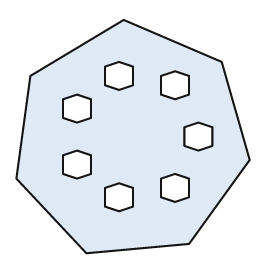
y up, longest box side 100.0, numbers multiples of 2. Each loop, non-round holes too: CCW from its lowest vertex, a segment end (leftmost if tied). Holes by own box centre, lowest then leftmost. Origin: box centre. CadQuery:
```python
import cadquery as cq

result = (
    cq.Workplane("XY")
    .moveTo(-20.0, -50.0)
    .lineTo(24.0, -46.0)
    .lineTo(50.0, -10.0)
    .lineTo(38.0, 32.0)
    .lineTo(-4.0, 50.0)
    .lineTo(-44.0, 26.0)
    .lineTo(-50.0, -18.0)
    .close()
    .moveTo(-6.0, -32.0)
    .lineTo(0.0, -30.0)
    .lineTo(0.0, -22.0)
    .lineTo(-6.0, -20.0)
    .lineTo(-12.0, -22.0)
    .lineTo(-12.0, -30.0)
    .close()
    .moveTo(18.0, -28.0)
    .lineTo(24.0, -26.0)
    .lineTo(24.0, -18.0)
    .lineTo(18.0, -16.0)
    .lineTo(12.0, -18.0)
    .lineTo(12.0, -26.0)
    .close()
    .moveTo(-24.0, -18.0)
    .lineTo(-18.0, -16.0)
    .lineTo(-18.0, -8.0)
    .lineTo(-24.0, -6.0)
    .lineTo(-30.0, -8.0)
    .lineTo(-30.0, -16.0)
    .close()
    .moveTo(28.0, -6.0)
    .lineTo(34.0, -4.0)
    .lineTo(34.0, 4.0)
    .lineTo(28.0, 6.0)
    .lineTo(22.0, 4.0)
    .lineTo(22.0, -4.0)
    .close()
    .moveTo(-24.0, 6.0)
    .lineTo(-18.0, 8.0)
    .lineTo(-18.0, 16.0)
    .lineTo(-24.0, 18.0)
    .lineTo(-30.0, 16.0)
    .lineTo(-30.0, 8.0)
    .close()
    .moveTo(18.0, 16.0)
    .lineTo(24.0, 18.0)
    .lineTo(24.0, 26.0)
    .lineTo(18.0, 28.0)
    .lineTo(12.0, 26.0)
    .lineTo(12.0, 18.0)
    .close()
    .moveTo(-6.0, 20.0)
    .lineTo(0.0, 22.0)
    .lineTo(0.0, 30.0)
    .lineTo(-6.0, 32.0)
    .lineTo(-12.0, 30.0)
    .lineTo(-12.0, 22.0)
    .close()
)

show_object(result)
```